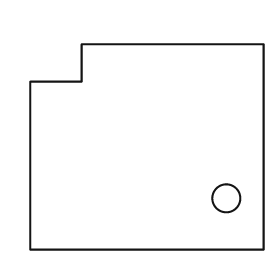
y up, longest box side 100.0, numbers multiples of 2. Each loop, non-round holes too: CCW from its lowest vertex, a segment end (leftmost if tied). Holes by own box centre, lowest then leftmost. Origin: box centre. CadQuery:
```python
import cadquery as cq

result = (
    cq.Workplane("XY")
    .moveTo(-50.0, -44.0)
    .lineTo(50.0, -44.0)
    .lineTo(50.0, 44.0)
    .lineTo(-28.0, 44.0)
    .lineTo(-28.0, 28.0)
    .lineTo(-50.0, 28.0)
    .close()
    .moveTo(34.0, -22.0)
    .circle(6.0)
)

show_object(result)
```